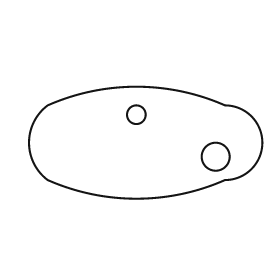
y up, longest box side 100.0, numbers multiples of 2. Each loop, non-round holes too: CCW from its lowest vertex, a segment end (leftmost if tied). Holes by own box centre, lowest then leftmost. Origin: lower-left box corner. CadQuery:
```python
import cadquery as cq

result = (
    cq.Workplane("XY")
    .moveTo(8.0, 8.0)
    .threePointArc((46.0, 0.0), (84.0, 8.0))
    .threePointArc((100.0, 24.0), (84.0, 40.0))
    .threePointArc((46.0, 48.0), (8.0, 40.0))
    .threePointArc((0.0, 24.0), (8.0, 8.0))
    .close()
    .moveTo(80.0, 18.0)
    .circle(6.0)
    .moveTo(46.0, 36.0)
    .circle(4.0)
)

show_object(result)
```